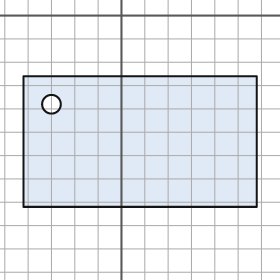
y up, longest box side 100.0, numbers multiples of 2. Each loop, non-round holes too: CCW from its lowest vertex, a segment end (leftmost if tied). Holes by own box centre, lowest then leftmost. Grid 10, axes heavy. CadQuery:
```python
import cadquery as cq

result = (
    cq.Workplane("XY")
    .moveTo(-42.0, -82.0)
    .lineTo(58.0, -82.0)
    .lineTo(58.0, -26.0)
    .lineTo(-42.0, -26.0)
    .close()
    .moveTo(-30.0, -38.0)
    .circle(4.0)
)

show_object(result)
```